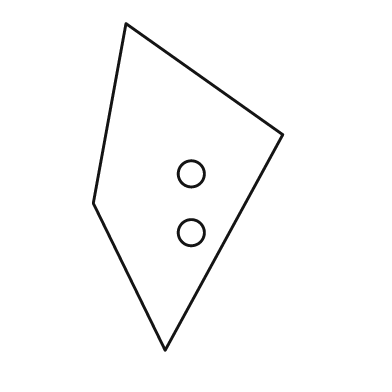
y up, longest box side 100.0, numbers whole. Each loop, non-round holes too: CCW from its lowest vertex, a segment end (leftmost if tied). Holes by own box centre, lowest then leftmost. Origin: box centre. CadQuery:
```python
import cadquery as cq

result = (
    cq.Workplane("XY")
    .moveTo(-7.0, -50.0)
    .lineTo(29.0, 16.0)
    .lineTo(-19.0, 50.0)
    .lineTo(-29.0, -5.0)
    .close()
    .moveTo(1.0, -14.0)
    .circle(4.0)
    .moveTo(1.0, 4.0)
    .circle(4.0)
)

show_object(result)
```